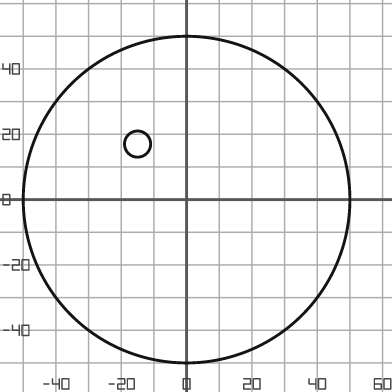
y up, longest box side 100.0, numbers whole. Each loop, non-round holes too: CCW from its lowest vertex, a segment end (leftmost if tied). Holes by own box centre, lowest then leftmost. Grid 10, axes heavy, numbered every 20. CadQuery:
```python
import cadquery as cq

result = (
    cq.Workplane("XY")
    .moveTo(0.0, 0.0)
    .circle(50.0)
    .moveTo(-15.0, 17.0)
    .circle(4.0)
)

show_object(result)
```